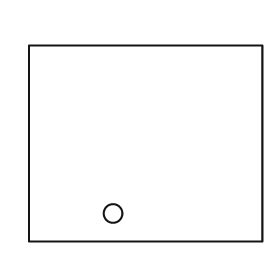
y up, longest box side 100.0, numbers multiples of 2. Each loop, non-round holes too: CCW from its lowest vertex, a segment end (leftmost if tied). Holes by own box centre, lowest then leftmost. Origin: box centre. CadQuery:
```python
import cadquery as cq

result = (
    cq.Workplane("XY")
    .moveTo(-50.0, -42.0)
    .lineTo(50.0, -42.0)
    .lineTo(50.0, 42.0)
    .lineTo(-50.0, 42.0)
    .close()
    .moveTo(-14.0, -30.0)
    .circle(4.0)
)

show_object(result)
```